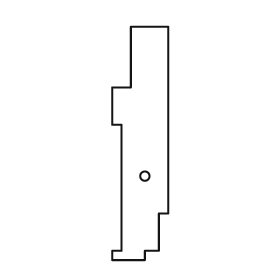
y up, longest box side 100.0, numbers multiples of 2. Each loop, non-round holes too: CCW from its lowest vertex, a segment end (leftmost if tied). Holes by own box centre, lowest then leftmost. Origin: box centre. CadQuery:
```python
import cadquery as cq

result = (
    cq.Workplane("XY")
    .moveTo(-12.0, -50.0)
    .lineTo(2.0, -50.0)
    .lineTo(2.0, -46.0)
    .lineTo(8.0, -46.0)
    .lineTo(8.0, -30.0)
    .lineTo(12.0, -30.0)
    .lineTo(12.0, 50.0)
    .lineTo(-4.0, 50.0)
    .lineTo(-4.0, 24.0)
    .lineTo(-12.0, 24.0)
    .lineTo(-12.0, 8.0)
    .lineTo(-8.0, 8.0)
    .lineTo(-8.0, -46.0)
    .lineTo(-12.0, -46.0)
    .close()
    .moveTo(2.0, -14.0)
    .circle(2.0)
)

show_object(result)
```